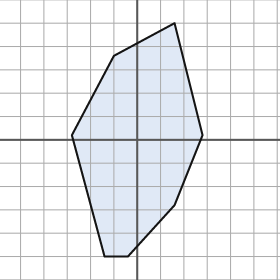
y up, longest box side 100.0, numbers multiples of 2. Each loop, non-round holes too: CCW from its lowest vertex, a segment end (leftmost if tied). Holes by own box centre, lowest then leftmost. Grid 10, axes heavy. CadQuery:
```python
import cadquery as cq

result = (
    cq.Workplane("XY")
    .moveTo(-14.0, -50.0)
    .lineTo(-4.0, -50.0)
    .lineTo(16.0, -28.0)
    .lineTo(28.0, 2.0)
    .lineTo(16.0, 50.0)
    .lineTo(-10.0, 36.0)
    .lineTo(-28.0, 2.0)
    .close()
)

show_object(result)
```